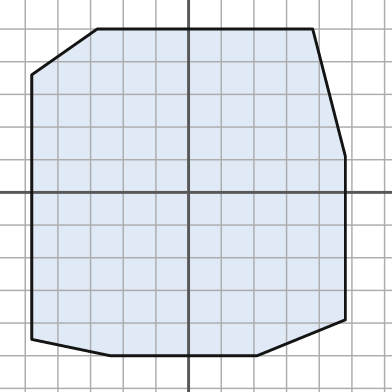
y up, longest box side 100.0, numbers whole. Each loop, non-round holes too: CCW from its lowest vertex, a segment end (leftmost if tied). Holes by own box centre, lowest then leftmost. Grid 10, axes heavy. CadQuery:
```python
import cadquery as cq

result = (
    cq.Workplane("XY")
    .moveTo(-24.0, -50.0)
    .lineTo(21.0, -50.0)
    .lineTo(48.0, -39.0)
    .lineTo(48.0, 11.0)
    .lineTo(38.0, 50.0)
    .lineTo(-28.0, 50.0)
    .lineTo(-48.0, 36.0)
    .lineTo(-48.0, -45.0)
    .close()
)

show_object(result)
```